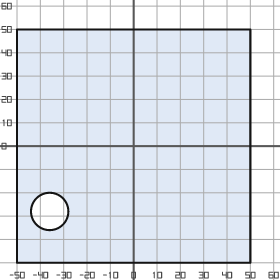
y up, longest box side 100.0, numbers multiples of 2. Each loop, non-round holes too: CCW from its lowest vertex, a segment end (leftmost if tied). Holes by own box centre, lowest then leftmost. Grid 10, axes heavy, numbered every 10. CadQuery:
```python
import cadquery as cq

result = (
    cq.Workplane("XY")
    .moveTo(-50.0, -50.0)
    .lineTo(50.0, -50.0)
    .lineTo(50.0, 50.0)
    .lineTo(-50.0, 50.0)
    .close()
    .moveTo(-36.0, -28.0)
    .circle(8.0)
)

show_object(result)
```